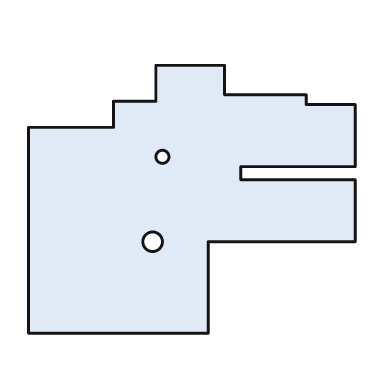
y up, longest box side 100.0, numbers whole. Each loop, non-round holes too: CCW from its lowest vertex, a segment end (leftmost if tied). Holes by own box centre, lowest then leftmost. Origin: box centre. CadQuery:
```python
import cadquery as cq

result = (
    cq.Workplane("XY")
    .moveTo(-50.0, -41.0)
    .lineTo(5.0, -41.0)
    .lineTo(5.0, -13.0)
    .lineTo(50.0, -13.0)
    .lineTo(50.0, 6.0)
    .lineTo(15.0, 6.0)
    .lineTo(15.0, 10.0)
    .lineTo(50.0, 10.0)
    .lineTo(50.0, 29.0)
    .lineTo(35.0, 29.0)
    .lineTo(35.0, 32.0)
    .lineTo(10.0, 32.0)
    .lineTo(10.0, 41.0)
    .lineTo(-11.0, 41.0)
    .lineTo(-11.0, 30.0)
    .lineTo(-24.0, 30.0)
    .lineTo(-24.0, 22.0)
    .lineTo(-50.0, 22.0)
    .close()
    .moveTo(-12.0, -13.0)
    .circle(3.0)
    .moveTo(-9.0, 13.0)
    .circle(2.0)
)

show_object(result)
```